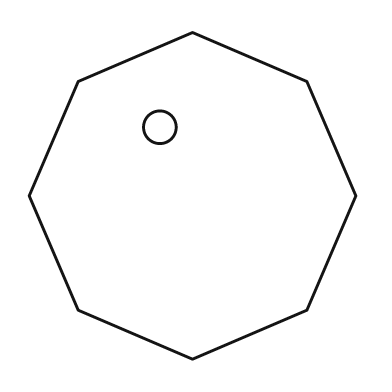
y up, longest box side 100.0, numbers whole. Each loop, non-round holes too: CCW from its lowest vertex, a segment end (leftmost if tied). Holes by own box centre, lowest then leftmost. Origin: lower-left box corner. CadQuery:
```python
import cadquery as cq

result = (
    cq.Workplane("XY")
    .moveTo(50.0, 0.0)
    .lineTo(85.0, 15.0)
    .lineTo(100.0, 50.0)
    .lineTo(85.0, 85.0)
    .lineTo(50.0, 100.0)
    .lineTo(15.0, 85.0)
    .lineTo(0.0, 50.0)
    .lineTo(15.0, 15.0)
    .close()
    .moveTo(40.0, 71.0)
    .circle(5.0)
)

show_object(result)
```